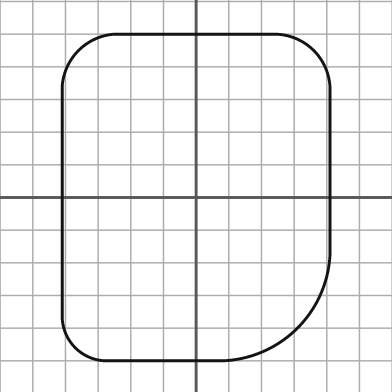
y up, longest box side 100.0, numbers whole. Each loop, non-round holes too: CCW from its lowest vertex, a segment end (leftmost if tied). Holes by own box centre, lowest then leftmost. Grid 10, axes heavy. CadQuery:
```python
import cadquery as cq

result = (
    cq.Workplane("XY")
    .moveTo(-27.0, -50.0)
    .lineTo(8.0, -50.0)
    .threePointArc((31.0, -40.0), (41.0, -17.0))
    .lineTo(41.0, 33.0)
    .threePointArc((36.0, 45.0), (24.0, 50.0))
    .lineTo(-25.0, 50.0)
    .threePointArc((-36.0, 45.0), (-41.0, 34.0))
    .lineTo(-41.0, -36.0)
    .threePointArc((-37.0, -46.0), (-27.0, -50.0))
    .close()
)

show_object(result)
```